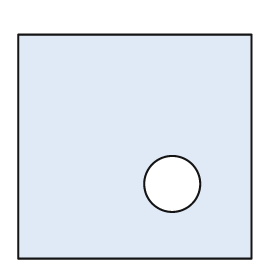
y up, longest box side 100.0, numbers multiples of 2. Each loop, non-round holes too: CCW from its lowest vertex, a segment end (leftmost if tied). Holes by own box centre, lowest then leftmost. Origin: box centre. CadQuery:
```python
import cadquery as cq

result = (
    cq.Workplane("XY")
    .moveTo(-50.0, -48.0)
    .lineTo(50.0, -48.0)
    .lineTo(50.0, 48.0)
    .lineTo(-50.0, 48.0)
    .close()
    .moveTo(16.0, -16.0)
    .circle(12.0)
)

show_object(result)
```